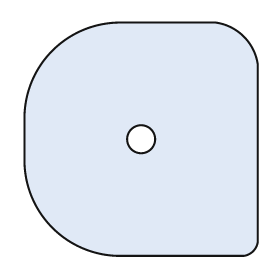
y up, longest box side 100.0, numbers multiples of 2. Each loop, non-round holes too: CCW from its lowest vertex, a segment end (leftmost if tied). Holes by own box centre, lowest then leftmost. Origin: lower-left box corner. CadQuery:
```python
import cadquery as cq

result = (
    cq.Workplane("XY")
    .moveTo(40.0, 0.0)
    .lineTo(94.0, 0.0)
    .threePointArc((98.0, 2.0), (100.0, 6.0))
    .lineTo(100.0, 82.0)
    .threePointArc((94.0, 94.0), (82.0, 100.0))
    .lineTo(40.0, 100.0)
    .threePointArc((12.0, 88.0), (0.0, 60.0))
    .lineTo(0.0, 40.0)
    .threePointArc((12.0, 12.0), (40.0, 0.0))
    .close()
    .moveTo(50.0, 50.0)
    .circle(6.0)
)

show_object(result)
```